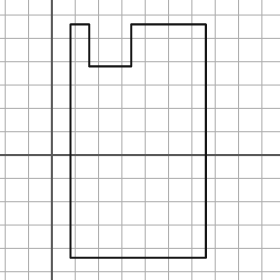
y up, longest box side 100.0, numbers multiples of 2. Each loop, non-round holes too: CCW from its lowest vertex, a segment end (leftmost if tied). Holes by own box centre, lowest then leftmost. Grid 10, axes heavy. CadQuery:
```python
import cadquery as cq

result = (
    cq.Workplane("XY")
    .moveTo(8.0, -44.0)
    .lineTo(66.0, -44.0)
    .lineTo(66.0, 56.0)
    .lineTo(34.0, 56.0)
    .lineTo(34.0, 38.0)
    .lineTo(16.0, 38.0)
    .lineTo(16.0, 56.0)
    .lineTo(8.0, 56.0)
    .close()
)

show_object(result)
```